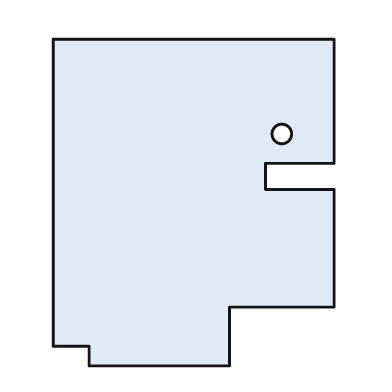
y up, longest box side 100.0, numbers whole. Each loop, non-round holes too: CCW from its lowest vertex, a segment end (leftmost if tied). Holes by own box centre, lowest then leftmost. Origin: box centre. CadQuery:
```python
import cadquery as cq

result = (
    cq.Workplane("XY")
    .moveTo(-32.0, -50.0)
    .lineTo(11.0, -50.0)
    .lineTo(11.0, -32.0)
    .lineTo(43.0, -32.0)
    .lineTo(43.0, 4.0)
    .lineTo(22.0, 4.0)
    .lineTo(22.0, 12.0)
    .lineTo(43.0, 12.0)
    .lineTo(43.0, 50.0)
    .lineTo(-43.0, 50.0)
    .lineTo(-43.0, -44.0)
    .lineTo(-32.0, -44.0)
    .close()
    .moveTo(27.0, 21.0)
    .circle(3.0)
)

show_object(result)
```